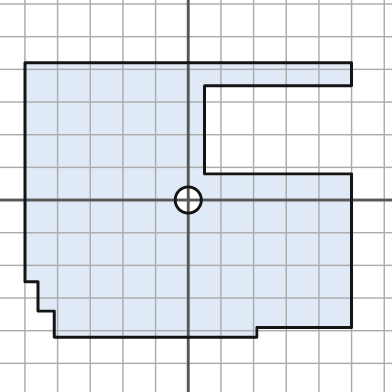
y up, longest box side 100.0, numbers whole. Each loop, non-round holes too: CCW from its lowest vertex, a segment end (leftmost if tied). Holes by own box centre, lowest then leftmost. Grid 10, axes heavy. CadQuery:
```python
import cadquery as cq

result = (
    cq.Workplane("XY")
    .moveTo(-41.0, -42.0)
    .lineTo(21.0, -42.0)
    .lineTo(21.0, -39.0)
    .lineTo(50.0, -39.0)
    .lineTo(50.0, 8.0)
    .lineTo(5.0, 8.0)
    .lineTo(5.0, 35.0)
    .lineTo(50.0, 35.0)
    .lineTo(50.0, 42.0)
    .lineTo(-50.0, 42.0)
    .lineTo(-50.0, -25.0)
    .lineTo(-46.0, -25.0)
    .lineTo(-46.0, -34.0)
    .lineTo(-41.0, -34.0)
    .close()
    .moveTo(0.0, 0.0)
    .circle(4.0)
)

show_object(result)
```